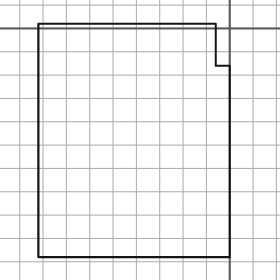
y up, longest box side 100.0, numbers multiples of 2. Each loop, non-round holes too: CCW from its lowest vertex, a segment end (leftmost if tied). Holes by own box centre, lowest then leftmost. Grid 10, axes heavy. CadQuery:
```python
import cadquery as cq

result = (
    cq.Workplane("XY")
    .moveTo(-82.0, -98.0)
    .lineTo(0.0, -98.0)
    .lineTo(0.0, -16.0)
    .lineTo(-6.0, -16.0)
    .lineTo(-6.0, 2.0)
    .lineTo(-82.0, 2.0)
    .close()
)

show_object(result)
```